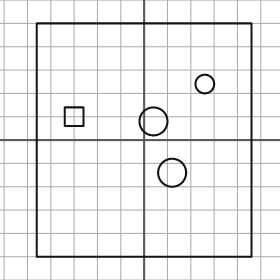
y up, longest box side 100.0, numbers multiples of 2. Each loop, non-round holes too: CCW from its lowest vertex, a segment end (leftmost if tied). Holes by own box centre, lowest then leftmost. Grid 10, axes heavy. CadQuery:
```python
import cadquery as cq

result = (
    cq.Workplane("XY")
    .moveTo(-46.0, -50.0)
    .lineTo(46.0, -50.0)
    .lineTo(46.0, 50.0)
    .lineTo(-46.0, 50.0)
    .close()
    .moveTo(12.0, -14.0)
    .circle(6.0)
    .moveTo(4.0, 8.0)
    .circle(6.0)
    .moveTo(-34.0, 6.0)
    .lineTo(-26.0, 6.0)
    .lineTo(-26.0, 14.0)
    .lineTo(-34.0, 14.0)
    .close()
    .moveTo(26.0, 24.0)
    .circle(4.0)
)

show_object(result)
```